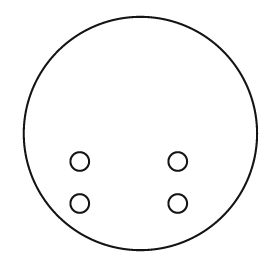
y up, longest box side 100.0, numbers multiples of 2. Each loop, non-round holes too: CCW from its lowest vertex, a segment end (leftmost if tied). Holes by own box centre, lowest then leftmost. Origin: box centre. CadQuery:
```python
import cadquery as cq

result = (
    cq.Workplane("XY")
    .moveTo(0.0, 0.0)
    .circle(50.0)
    .moveTo(-26.0, -30.0)
    .circle(4.0)
    .moveTo(16.0, -30.0)
    .circle(4.0)
    .moveTo(-26.0, -12.0)
    .circle(4.0)
    .moveTo(16.0, -12.0)
    .circle(4.0)
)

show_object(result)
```